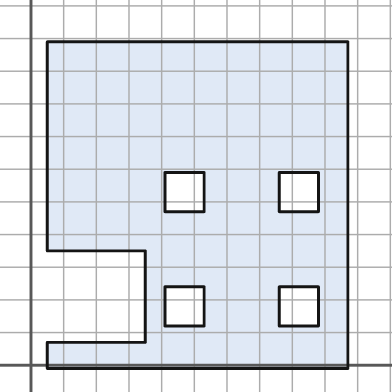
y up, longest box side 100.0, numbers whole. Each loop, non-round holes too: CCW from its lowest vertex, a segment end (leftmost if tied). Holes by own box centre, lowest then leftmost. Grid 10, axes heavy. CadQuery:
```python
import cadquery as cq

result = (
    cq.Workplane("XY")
    .moveTo(5.0, -1.0)
    .lineTo(97.0, -1.0)
    .lineTo(97.0, 99.0)
    .lineTo(5.0, 99.0)
    .lineTo(5.0, 35.0)
    .lineTo(35.0, 35.0)
    .lineTo(35.0, 7.0)
    .lineTo(5.0, 7.0)
    .close()
    .moveTo(41.0, 12.0)
    .lineTo(53.0, 12.0)
    .lineTo(53.0, 24.0)
    .lineTo(41.0, 24.0)
    .close()
    .moveTo(76.0, 12.0)
    .lineTo(88.0, 12.0)
    .lineTo(88.0, 24.0)
    .lineTo(76.0, 24.0)
    .close()
    .moveTo(41.0, 47.0)
    .lineTo(53.0, 47.0)
    .lineTo(53.0, 59.0)
    .lineTo(41.0, 59.0)
    .close()
    .moveTo(76.0, 47.0)
    .lineTo(88.0, 47.0)
    .lineTo(88.0, 59.0)
    .lineTo(76.0, 59.0)
    .close()
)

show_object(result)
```